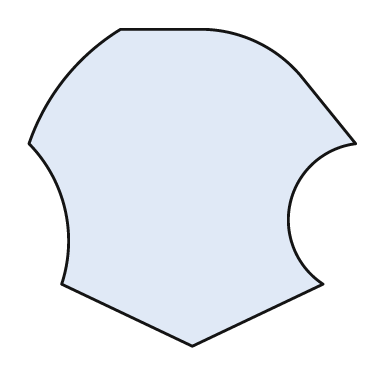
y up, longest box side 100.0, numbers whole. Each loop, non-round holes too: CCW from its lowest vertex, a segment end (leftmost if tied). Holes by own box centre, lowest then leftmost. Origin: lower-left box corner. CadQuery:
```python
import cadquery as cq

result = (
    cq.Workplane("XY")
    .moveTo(50.0, 0.0)
    .lineTo(90.0, 19.0)
    .threePointArc((80.0, 44.0), (100.0, 62.0))
    .lineTo(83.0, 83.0)
    .threePointArc((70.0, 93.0), (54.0, 97.0))
    .lineTo(28.0, 97.0)
    .threePointArc((11.0, 82.0), (0.0, 62.0))
    .threePointArc((11.0, 42.0), (10.0, 19.0))
    .close()
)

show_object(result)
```